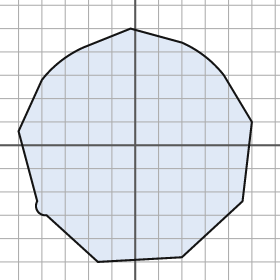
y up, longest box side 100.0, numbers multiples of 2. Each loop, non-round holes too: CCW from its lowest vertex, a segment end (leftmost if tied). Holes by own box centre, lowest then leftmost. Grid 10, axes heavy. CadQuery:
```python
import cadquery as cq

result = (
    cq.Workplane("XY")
    .moveTo(-16.0, -50.0)
    .lineTo(20.0, -48.0)
    .lineTo(46.0, -24.0)
    .lineTo(50.0, 10.0)
    .lineTo(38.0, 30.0)
    .threePointArc((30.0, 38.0), (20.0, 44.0))
    .lineTo(-2.0, 50.0)
    .lineTo(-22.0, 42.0)
    .threePointArc((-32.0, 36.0), (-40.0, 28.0))
    .lineTo(-50.0, 6.0)
    .lineTo(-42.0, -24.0)
    .threePointArc((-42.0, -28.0), (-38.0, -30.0))
    .close()
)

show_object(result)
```